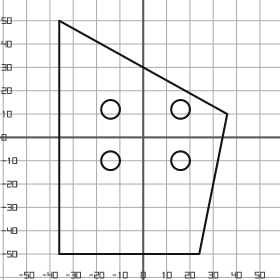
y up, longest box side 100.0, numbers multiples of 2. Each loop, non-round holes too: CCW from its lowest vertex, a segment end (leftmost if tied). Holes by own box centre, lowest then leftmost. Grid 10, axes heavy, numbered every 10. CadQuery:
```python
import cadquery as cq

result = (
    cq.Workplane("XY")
    .moveTo(-36.0, -50.0)
    .lineTo(24.0, -50.0)
    .lineTo(36.0, 10.0)
    .lineTo(-36.0, 50.0)
    .close()
    .moveTo(-14.0, -10.0)
    .circle(4.0)
    .moveTo(16.0, -10.0)
    .circle(4.0)
    .moveTo(-14.0, 12.0)
    .circle(4.0)
    .moveTo(16.0, 12.0)
    .circle(4.0)
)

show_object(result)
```